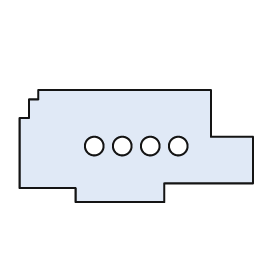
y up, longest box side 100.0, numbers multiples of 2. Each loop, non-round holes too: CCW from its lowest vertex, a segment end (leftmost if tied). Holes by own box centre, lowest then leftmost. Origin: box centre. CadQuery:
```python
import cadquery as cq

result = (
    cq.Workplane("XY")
    .moveTo(-26.0, -24.0)
    .lineTo(12.0, -24.0)
    .lineTo(12.0, -16.0)
    .lineTo(50.0, -16.0)
    .lineTo(50.0, 4.0)
    .lineTo(32.0, 4.0)
    .lineTo(32.0, 24.0)
    .lineTo(-42.0, 24.0)
    .lineTo(-42.0, 20.0)
    .lineTo(-46.0, 20.0)
    .lineTo(-46.0, 12.0)
    .lineTo(-50.0, 12.0)
    .lineTo(-50.0, -18.0)
    .lineTo(-26.0, -18.0)
    .close()
    .moveTo(-18.0, 0.0)
    .circle(4.0)
    .moveTo(-6.0, 0.0)
    .circle(4.0)
    .moveTo(6.0, 0.0)
    .circle(4.0)
    .moveTo(18.0, 0.0)
    .circle(4.0)
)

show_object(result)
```